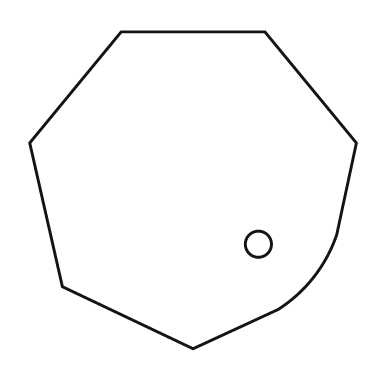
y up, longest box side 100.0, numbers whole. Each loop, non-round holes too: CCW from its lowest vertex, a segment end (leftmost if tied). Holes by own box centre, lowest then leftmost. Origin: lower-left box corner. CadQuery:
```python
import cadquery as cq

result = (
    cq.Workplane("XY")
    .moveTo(50.0, 0.0)
    .lineTo(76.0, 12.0)
    .threePointArc((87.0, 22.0), (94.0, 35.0))
    .lineTo(100.0, 63.0)
    .lineTo(72.0, 97.0)
    .lineTo(28.0, 97.0)
    .lineTo(0.0, 63.0)
    .lineTo(10.0, 19.0)
    .close()
    .moveTo(70.0, 32.0)
    .circle(4.0)
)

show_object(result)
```